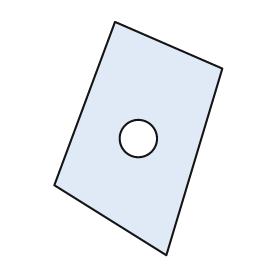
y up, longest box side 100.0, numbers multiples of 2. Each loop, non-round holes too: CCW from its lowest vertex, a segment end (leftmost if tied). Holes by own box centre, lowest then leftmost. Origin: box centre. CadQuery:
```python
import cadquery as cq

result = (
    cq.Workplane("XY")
    .moveTo(12.0, -50.0)
    .lineTo(36.0, 30.0)
    .lineTo(-10.0, 50.0)
    .lineTo(-36.0, -20.0)
    .close()
    .moveTo(0.0, 0.0)
    .circle(8.0)
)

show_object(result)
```